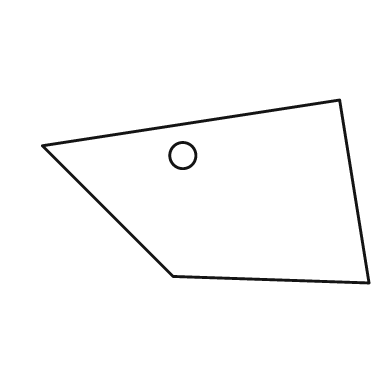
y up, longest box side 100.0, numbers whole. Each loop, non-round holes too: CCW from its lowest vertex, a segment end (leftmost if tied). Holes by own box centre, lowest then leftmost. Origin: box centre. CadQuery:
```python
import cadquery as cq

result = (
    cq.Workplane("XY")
    .moveTo(50.0, -28.0)
    .lineTo(41.0, 28.0)
    .lineTo(-50.0, 14.0)
    .lineTo(-10.0, -26.0)
    .close()
    .moveTo(-7.0, 11.0)
    .circle(4.0)
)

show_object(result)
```